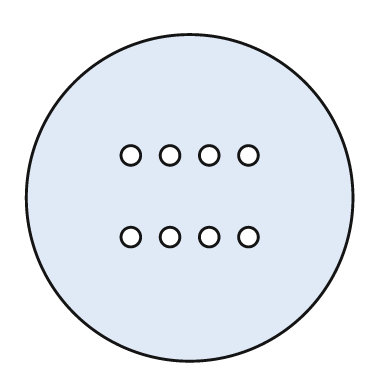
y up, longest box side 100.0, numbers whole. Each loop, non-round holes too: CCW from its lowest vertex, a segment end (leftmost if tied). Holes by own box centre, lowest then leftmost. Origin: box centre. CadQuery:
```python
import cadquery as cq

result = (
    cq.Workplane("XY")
    .moveTo(0.0, 0.0)
    .circle(50.0)
    .moveTo(-18.0, -12.0)
    .circle(3.0)
    .moveTo(-6.0, -12.0)
    .circle(3.0)
    .moveTo(6.0, -12.0)
    .circle(3.0)
    .moveTo(18.0, -12.0)
    .circle(3.0)
    .moveTo(-18.0, 13.0)
    .circle(3.0)
    .moveTo(-6.0, 13.0)
    .circle(3.0)
    .moveTo(6.0, 13.0)
    .circle(3.0)
    .moveTo(18.0, 13.0)
    .circle(3.0)
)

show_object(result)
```